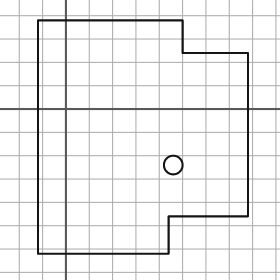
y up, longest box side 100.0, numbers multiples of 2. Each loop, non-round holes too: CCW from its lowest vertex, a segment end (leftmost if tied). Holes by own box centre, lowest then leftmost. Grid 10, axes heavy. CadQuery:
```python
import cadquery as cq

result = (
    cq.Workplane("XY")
    .moveTo(-12.0, -62.0)
    .lineTo(44.0, -62.0)
    .lineTo(44.0, -46.0)
    .lineTo(78.0, -46.0)
    .lineTo(78.0, 24.0)
    .lineTo(50.0, 24.0)
    .lineTo(50.0, 38.0)
    .lineTo(-12.0, 38.0)
    .close()
    .moveTo(46.0, -24.0)
    .circle(4.0)
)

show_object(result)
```